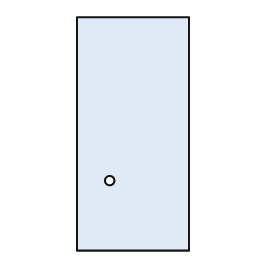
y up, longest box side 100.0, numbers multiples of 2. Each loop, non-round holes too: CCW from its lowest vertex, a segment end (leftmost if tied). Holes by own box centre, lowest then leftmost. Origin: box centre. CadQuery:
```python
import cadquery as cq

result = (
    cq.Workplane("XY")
    .moveTo(-24.0, -50.0)
    .lineTo(24.0, -50.0)
    .lineTo(24.0, 50.0)
    .lineTo(-24.0, 50.0)
    .close()
    .moveTo(-10.0, -20.0)
    .circle(2.0)
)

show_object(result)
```